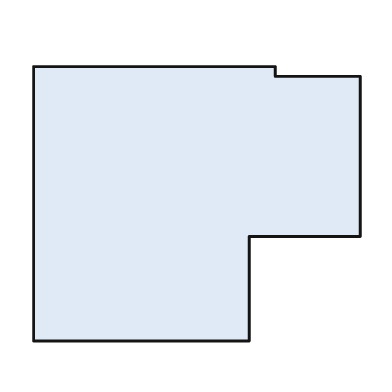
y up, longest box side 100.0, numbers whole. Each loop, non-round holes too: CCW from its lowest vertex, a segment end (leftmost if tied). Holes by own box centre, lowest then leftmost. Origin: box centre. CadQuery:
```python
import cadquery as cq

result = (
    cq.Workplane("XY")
    .moveTo(-50.0, -42.0)
    .lineTo(16.0, -42.0)
    .lineTo(16.0, -10.0)
    .lineTo(50.0, -10.0)
    .lineTo(50.0, 39.0)
    .lineTo(24.0, 39.0)
    .lineTo(24.0, 42.0)
    .lineTo(-50.0, 42.0)
    .close()
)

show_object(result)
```